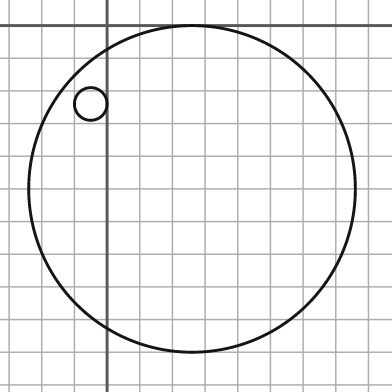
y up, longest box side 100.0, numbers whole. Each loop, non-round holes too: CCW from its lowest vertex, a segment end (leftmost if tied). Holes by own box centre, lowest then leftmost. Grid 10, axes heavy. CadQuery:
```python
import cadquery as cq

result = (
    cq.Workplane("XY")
    .moveTo(26.0, -50.0)
    .circle(50.0)
    .moveTo(-5.0, -24.0)
    .circle(5.0)
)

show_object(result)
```